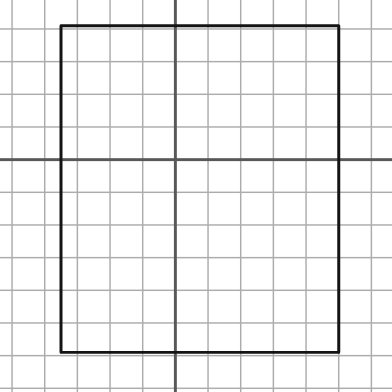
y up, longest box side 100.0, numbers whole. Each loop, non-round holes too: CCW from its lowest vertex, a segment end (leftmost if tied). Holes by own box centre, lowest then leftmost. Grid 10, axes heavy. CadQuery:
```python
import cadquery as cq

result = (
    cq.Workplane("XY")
    .moveTo(-35.0, -59.0)
    .lineTo(50.0, -59.0)
    .lineTo(50.0, 41.0)
    .lineTo(-35.0, 41.0)
    .close()
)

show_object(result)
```